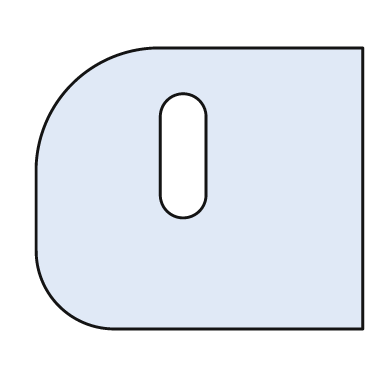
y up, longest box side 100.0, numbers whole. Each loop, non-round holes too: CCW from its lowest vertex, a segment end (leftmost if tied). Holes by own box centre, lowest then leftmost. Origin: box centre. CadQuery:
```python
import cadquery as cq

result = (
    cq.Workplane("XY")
    .moveTo(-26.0, -43.0)
    .lineTo(50.0, -43.0)
    .lineTo(50.0, 43.0)
    .lineTo(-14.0, 43.0)
    .threePointArc((-39.0, 32.0), (-50.0, 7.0))
    .lineTo(-50.0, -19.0)
    .threePointArc((-43.0, -36.0), (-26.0, -43.0))
    .close()
    .moveTo(-12.0, -2.0)
    .threePointArc((-5.0, -9.0), (2.0, -2.0))
    .lineTo(2.0, 22.0)
    .threePointArc((-5.0, 29.0), (-12.0, 22.0))
    .close()
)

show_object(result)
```